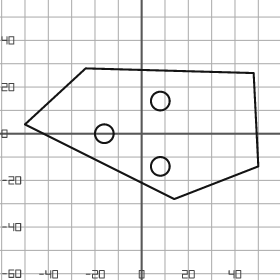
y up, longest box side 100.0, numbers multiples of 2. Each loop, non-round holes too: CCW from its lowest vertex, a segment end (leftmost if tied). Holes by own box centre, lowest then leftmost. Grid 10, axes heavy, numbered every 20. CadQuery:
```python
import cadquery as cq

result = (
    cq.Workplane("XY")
    .moveTo(14.0, -28.0)
    .lineTo(50.0, -14.0)
    .lineTo(48.0, 26.0)
    .lineTo(-24.0, 28.0)
    .lineTo(-50.0, 4.0)
    .close()
    .moveTo(8.0, -14.0)
    .circle(4.0)
    .moveTo(-16.0, 0.0)
    .circle(4.0)
    .moveTo(8.0, 14.0)
    .circle(4.0)
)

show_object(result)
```